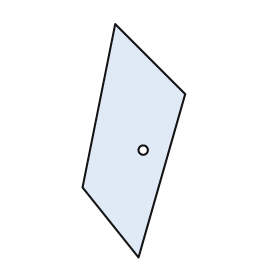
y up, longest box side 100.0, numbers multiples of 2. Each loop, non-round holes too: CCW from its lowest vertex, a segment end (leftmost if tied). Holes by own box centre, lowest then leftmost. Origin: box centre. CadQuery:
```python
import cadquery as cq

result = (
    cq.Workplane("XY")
    .moveTo(2.0, -50.0)
    .lineTo(22.0, 20.0)
    .lineTo(-8.0, 50.0)
    .lineTo(-22.0, -20.0)
    .close()
    .moveTo(4.0, -4.0)
    .circle(2.0)
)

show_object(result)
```